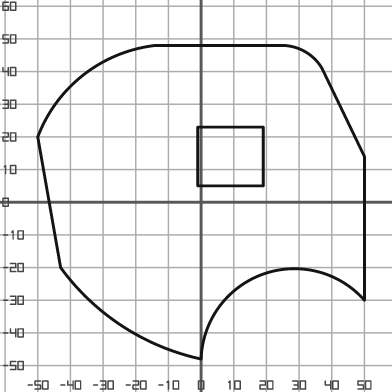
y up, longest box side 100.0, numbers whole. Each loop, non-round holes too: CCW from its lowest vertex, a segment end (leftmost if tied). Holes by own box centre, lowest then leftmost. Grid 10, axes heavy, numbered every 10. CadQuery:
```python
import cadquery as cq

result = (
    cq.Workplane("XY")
    .moveTo(0.0, -48.0)
    .threePointArc((19.0, -22.0), (50.0, -30.0))
    .lineTo(50.0, 14.0)
    .lineTo(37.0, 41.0)
    .threePointArc((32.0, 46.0), (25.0, 48.0))
    .lineTo(-14.0, 48.0)
    .threePointArc((-36.0, 39.0), (-50.0, 20.0))
    .lineTo(-43.0, -20.0)
    .threePointArc((-24.0, -38.0), (0.0, -48.0))
    .close()
    .moveTo(-1.0, 5.0)
    .lineTo(19.0, 5.0)
    .lineTo(19.0, 23.0)
    .lineTo(-1.0, 23.0)
    .close()
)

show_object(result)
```